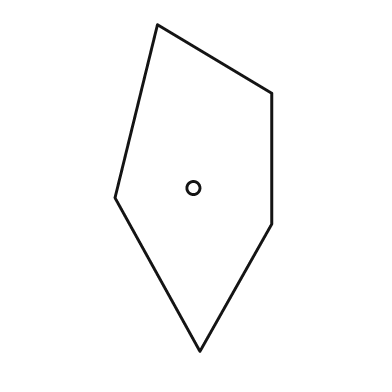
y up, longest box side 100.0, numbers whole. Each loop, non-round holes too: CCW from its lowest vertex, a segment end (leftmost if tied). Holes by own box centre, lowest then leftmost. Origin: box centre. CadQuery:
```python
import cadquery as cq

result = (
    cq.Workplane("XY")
    .moveTo(2.0, -50.0)
    .lineTo(24.0, -11.0)
    .lineTo(24.0, 29.0)
    .lineTo(-11.0, 50.0)
    .lineTo(-24.0, -3.0)
    .close()
    .moveTo(0.0, 0.0)
    .circle(2.0)
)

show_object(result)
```